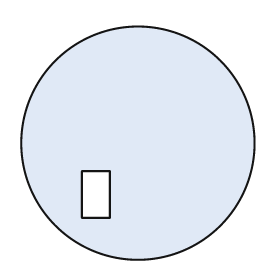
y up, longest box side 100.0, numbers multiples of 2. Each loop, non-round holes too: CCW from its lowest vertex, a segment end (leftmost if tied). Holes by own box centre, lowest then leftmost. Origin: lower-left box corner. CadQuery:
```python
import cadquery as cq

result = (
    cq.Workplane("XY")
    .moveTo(50.0, 50.0)
    .circle(50.0)
    .moveTo(26.0, 18.0)
    .lineTo(38.0, 18.0)
    .lineTo(38.0, 38.0)
    .lineTo(26.0, 38.0)
    .close()
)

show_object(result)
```